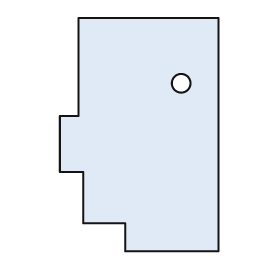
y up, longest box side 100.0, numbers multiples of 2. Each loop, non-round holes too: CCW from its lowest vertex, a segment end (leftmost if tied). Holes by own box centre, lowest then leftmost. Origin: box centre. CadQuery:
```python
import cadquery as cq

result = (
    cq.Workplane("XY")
    .moveTo(-6.0, -50.0)
    .lineTo(34.0, -50.0)
    .lineTo(34.0, 50.0)
    .lineTo(-26.0, 50.0)
    .lineTo(-26.0, 8.0)
    .lineTo(-34.0, 8.0)
    .lineTo(-34.0, -16.0)
    .lineTo(-24.0, -16.0)
    .lineTo(-24.0, -38.0)
    .lineTo(-6.0, -38.0)
    .close()
    .moveTo(18.0, 22.0)
    .circle(4.0)
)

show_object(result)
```